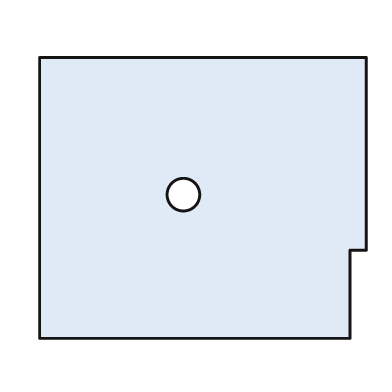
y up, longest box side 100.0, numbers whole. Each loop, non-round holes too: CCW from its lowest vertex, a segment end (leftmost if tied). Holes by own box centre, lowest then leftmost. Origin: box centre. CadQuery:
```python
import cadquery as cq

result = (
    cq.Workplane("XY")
    .moveTo(-50.0, -43.0)
    .lineTo(45.0, -43.0)
    .lineTo(45.0, -16.0)
    .lineTo(50.0, -16.0)
    .lineTo(50.0, 43.0)
    .lineTo(-50.0, 43.0)
    .close()
    .moveTo(-6.0, 1.0)
    .circle(5.0)
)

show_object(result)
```